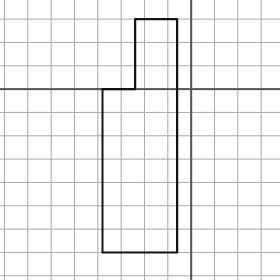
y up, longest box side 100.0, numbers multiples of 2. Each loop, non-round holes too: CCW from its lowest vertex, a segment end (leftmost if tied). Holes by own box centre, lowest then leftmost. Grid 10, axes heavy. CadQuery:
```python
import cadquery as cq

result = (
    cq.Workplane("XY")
    .moveTo(-38.0, -70.0)
    .lineTo(-6.0, -70.0)
    .lineTo(-6.0, 30.0)
    .lineTo(-24.0, 30.0)
    .lineTo(-24.0, 0.0)
    .lineTo(-38.0, 0.0)
    .close()
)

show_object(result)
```